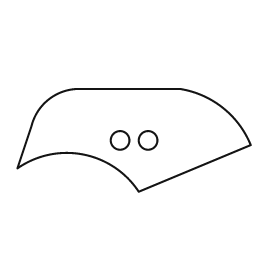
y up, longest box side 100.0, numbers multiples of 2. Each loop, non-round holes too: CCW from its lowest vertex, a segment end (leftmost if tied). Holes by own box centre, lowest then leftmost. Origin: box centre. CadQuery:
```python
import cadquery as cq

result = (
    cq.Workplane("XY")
    .moveTo(2.0, -22.0)
    .lineTo(50.0, -2.0)
    .threePointArc((38.0, 14.0), (20.0, 22.0))
    .lineTo(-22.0, 22.0)
    .threePointArc((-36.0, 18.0), (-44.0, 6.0))
    .lineTo(-50.0, -12.0)
    .threePointArc((-22.0, -6.0), (2.0, -22.0))
    .close()
    .moveTo(-6.0, 0.0)
    .circle(4.0)
    .moveTo(6.0, 0.0)
    .circle(4.0)
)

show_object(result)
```